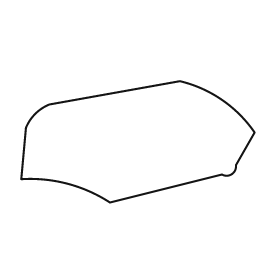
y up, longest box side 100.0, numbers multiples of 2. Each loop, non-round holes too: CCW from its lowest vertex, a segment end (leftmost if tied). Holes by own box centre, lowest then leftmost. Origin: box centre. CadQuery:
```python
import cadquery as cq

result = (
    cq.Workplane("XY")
    .moveTo(-12.0, -26.0)
    .lineTo(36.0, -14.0)
    .threePointArc((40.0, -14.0), (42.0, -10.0))
    .lineTo(50.0, 4.0)
    .threePointArc((36.0, 18.0), (18.0, 26.0))
    .lineTo(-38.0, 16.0)
    .threePointArc((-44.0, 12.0), (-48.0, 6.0))
    .lineTo(-50.0, -16.0)
    .threePointArc((-30.0, -18.0), (-12.0, -26.0))
    .close()
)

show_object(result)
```